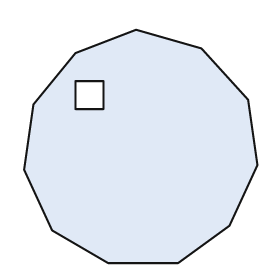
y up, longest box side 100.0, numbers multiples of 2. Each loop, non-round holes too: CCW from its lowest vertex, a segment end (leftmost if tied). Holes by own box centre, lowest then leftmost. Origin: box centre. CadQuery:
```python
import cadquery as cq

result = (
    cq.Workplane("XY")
    .moveTo(-14.0, -50.0)
    .lineTo(16.0, -50.0)
    .lineTo(38.0, -34.0)
    .lineTo(50.0, -8.0)
    .lineTo(46.0, 20.0)
    .lineTo(26.0, 42.0)
    .lineTo(-2.0, 50.0)
    .lineTo(-28.0, 40.0)
    .lineTo(-46.0, 18.0)
    .lineTo(-50.0, -10.0)
    .lineTo(-38.0, -36.0)
    .close()
    .moveTo(-28.0, 16.0)
    .lineTo(-16.0, 16.0)
    .lineTo(-16.0, 28.0)
    .lineTo(-28.0, 28.0)
    .close()
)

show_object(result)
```